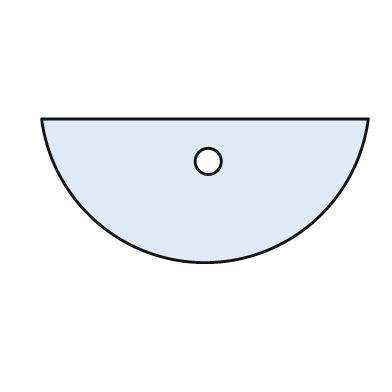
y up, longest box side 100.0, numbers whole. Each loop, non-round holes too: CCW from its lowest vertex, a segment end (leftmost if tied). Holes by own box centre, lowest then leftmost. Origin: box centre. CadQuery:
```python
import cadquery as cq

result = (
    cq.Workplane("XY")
    .moveTo(-50.0, 22.0)
    .threePointArc((0.0, -22.0), (50.0, 22.0))
    .close()
    .moveTo(1.0, 9.0)
    .circle(4.0)
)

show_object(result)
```